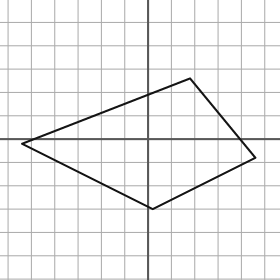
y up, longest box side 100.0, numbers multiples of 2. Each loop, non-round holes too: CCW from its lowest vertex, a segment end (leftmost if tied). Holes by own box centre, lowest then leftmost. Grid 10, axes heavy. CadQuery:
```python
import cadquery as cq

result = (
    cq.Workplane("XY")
    .moveTo(2.0, -30.0)
    .lineTo(46.0, -8.0)
    .lineTo(18.0, 26.0)
    .lineTo(-54.0, -2.0)
    .close()
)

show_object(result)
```